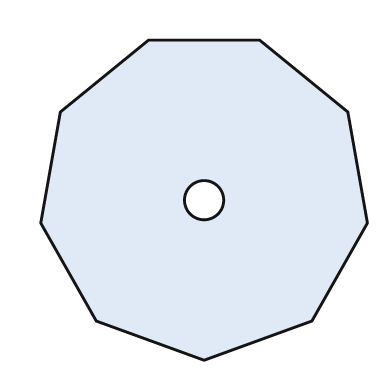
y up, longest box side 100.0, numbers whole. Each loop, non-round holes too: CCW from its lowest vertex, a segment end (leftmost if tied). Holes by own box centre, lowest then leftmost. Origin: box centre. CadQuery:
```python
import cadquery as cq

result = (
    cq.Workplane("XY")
    .moveTo(0.0, -49.0)
    .lineTo(33.0, -37.0)
    .lineTo(50.0, -7.0)
    .lineTo(44.0, 27.0)
    .lineTo(17.0, 49.0)
    .lineTo(-17.0, 49.0)
    .lineTo(-44.0, 27.0)
    .lineTo(-50.0, -7.0)
    .lineTo(-33.0, -37.0)
    .close()
    .moveTo(0.0, 0.0)
    .circle(6.0)
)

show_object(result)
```